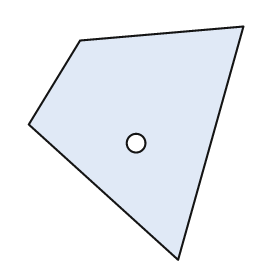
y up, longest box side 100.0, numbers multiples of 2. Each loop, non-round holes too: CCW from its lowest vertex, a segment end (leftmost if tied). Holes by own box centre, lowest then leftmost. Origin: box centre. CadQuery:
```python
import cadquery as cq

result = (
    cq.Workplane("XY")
    .moveTo(18.0, -50.0)
    .lineTo(46.0, 50.0)
    .lineTo(-24.0, 44.0)
    .lineTo(-46.0, 8.0)
    .close()
    .moveTo(0.0, 0.0)
    .circle(4.0)
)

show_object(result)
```